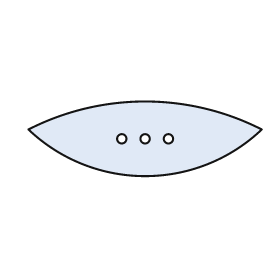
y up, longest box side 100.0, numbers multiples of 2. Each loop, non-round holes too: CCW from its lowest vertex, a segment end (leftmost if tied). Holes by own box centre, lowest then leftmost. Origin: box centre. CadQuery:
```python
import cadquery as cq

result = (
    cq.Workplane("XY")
    .moveTo(-50.0, 4.0)
    .threePointArc((0.0, -16.0), (50.0, 4.0))
    .threePointArc((0.0, 16.0), (-50.0, 4.0))
    .close()
    .moveTo(-10.0, 0.0)
    .circle(2.0)
    .moveTo(0.0, 0.0)
    .circle(2.0)
    .moveTo(10.0, 0.0)
    .circle(2.0)
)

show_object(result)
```